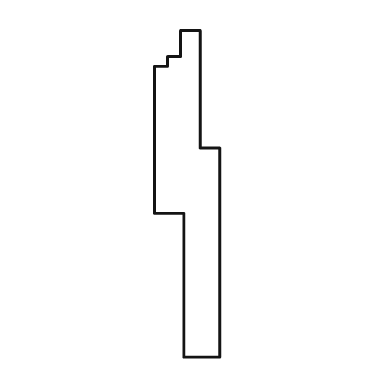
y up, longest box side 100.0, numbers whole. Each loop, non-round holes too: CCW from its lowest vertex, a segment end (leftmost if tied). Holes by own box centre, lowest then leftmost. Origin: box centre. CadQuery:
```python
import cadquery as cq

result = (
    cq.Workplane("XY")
    .moveTo(-1.0, -50.0)
    .lineTo(10.0, -50.0)
    .lineTo(10.0, 14.0)
    .lineTo(4.0, 14.0)
    .lineTo(4.0, 50.0)
    .lineTo(-2.0, 50.0)
    .lineTo(-2.0, 42.0)
    .lineTo(-6.0, 42.0)
    .lineTo(-6.0, 39.0)
    .lineTo(-10.0, 39.0)
    .lineTo(-10.0, -6.0)
    .lineTo(-1.0, -6.0)
    .close()
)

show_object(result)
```